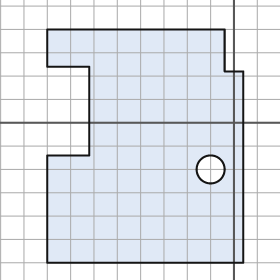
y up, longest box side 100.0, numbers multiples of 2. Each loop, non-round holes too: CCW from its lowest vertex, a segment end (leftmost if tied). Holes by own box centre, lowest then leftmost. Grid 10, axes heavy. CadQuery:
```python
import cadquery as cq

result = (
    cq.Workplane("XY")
    .moveTo(-80.0, -60.0)
    .lineTo(4.0, -60.0)
    .lineTo(4.0, 22.0)
    .lineTo(-4.0, 22.0)
    .lineTo(-4.0, 40.0)
    .lineTo(-80.0, 40.0)
    .lineTo(-80.0, 24.0)
    .lineTo(-62.0, 24.0)
    .lineTo(-62.0, -14.0)
    .lineTo(-80.0, -14.0)
    .close()
    .moveTo(-10.0, -20.0)
    .circle(6.0)
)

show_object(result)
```